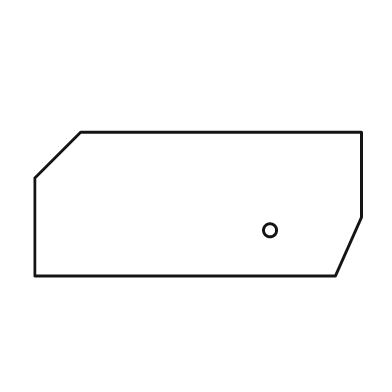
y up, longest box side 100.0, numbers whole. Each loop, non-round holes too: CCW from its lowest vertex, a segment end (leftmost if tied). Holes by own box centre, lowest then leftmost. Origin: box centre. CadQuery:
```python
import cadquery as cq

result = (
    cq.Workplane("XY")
    .moveTo(-50.0, -22.0)
    .lineTo(42.0, -22.0)
    .lineTo(50.0, -4.0)
    .lineTo(50.0, 22.0)
    .lineTo(-36.0, 22.0)
    .lineTo(-50.0, 8.0)
    .close()
    .moveTo(22.0, -8.0)
    .circle(2.0)
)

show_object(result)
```